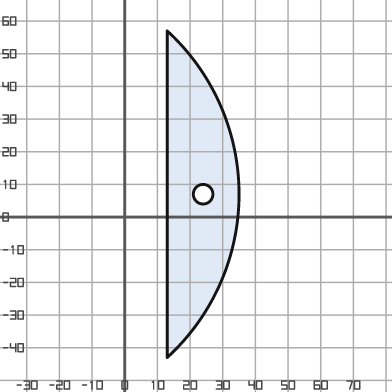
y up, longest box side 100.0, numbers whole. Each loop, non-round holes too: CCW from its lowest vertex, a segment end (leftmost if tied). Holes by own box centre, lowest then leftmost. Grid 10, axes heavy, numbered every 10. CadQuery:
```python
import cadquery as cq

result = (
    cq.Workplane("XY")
    .moveTo(13.0, -43.0)
    .threePointArc((35.0, 7.0), (13.0, 57.0))
    .close()
    .moveTo(24.0, 7.0)
    .circle(3.0)
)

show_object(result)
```